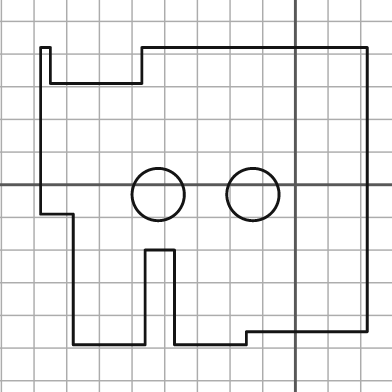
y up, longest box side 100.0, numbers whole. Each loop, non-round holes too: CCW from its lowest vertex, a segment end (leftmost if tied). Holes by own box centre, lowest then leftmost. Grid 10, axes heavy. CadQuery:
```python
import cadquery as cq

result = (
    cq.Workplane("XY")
    .moveTo(-68.0, -49.0)
    .lineTo(-46.0, -49.0)
    .lineTo(-46.0, -20.0)
    .lineTo(-37.0, -20.0)
    .lineTo(-37.0, -49.0)
    .lineTo(-15.0, -49.0)
    .lineTo(-15.0, -45.0)
    .lineTo(22.0, -45.0)
    .lineTo(22.0, 42.0)
    .lineTo(-47.0, 42.0)
    .lineTo(-47.0, 31.0)
    .lineTo(-75.0, 31.0)
    .lineTo(-75.0, 42.0)
    .lineTo(-78.0, 42.0)
    .lineTo(-78.0, -9.0)
    .lineTo(-68.0, -9.0)
    .close()
    .moveTo(-42.0, -3.0)
    .circle(8.0)
    .moveTo(-13.0, -3.0)
    .circle(8.0)
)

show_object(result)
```